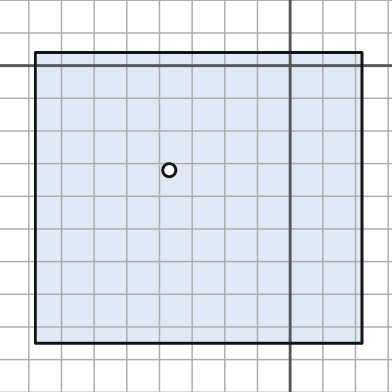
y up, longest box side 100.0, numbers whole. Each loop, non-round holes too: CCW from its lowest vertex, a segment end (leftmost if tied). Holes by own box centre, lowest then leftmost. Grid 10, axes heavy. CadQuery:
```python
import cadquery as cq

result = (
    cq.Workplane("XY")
    .moveTo(-78.0, -85.0)
    .lineTo(22.0, -85.0)
    .lineTo(22.0, 4.0)
    .lineTo(-78.0, 4.0)
    .close()
    .moveTo(-37.0, -32.0)
    .circle(2.0)
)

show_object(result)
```